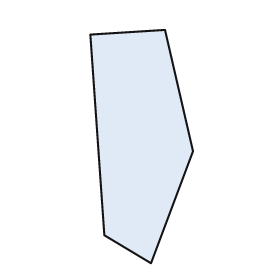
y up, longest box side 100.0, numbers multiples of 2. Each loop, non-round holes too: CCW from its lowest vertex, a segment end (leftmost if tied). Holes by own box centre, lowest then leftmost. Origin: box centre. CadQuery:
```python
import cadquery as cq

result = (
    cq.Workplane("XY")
    .moveTo(4.0, -50.0)
    .lineTo(22.0, -2.0)
    .lineTo(10.0, 50.0)
    .lineTo(-22.0, 48.0)
    .lineTo(-16.0, -38.0)
    .close()
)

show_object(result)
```